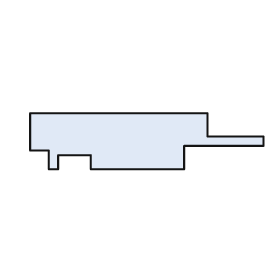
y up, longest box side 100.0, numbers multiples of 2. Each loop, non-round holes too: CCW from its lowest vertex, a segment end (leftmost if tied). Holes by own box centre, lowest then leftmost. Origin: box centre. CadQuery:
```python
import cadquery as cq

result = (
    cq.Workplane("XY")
    .moveTo(-42.0, -12.0)
    .lineTo(-38.0, -12.0)
    .lineTo(-38.0, -6.0)
    .lineTo(-24.0, -6.0)
    .lineTo(-24.0, -12.0)
    .lineTo(16.0, -12.0)
    .lineTo(16.0, -2.0)
    .lineTo(50.0, -2.0)
    .lineTo(50.0, 2.0)
    .lineTo(26.0, 2.0)
    .lineTo(26.0, 12.0)
    .lineTo(-50.0, 12.0)
    .lineTo(-50.0, -4.0)
    .lineTo(-42.0, -4.0)
    .close()
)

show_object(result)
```